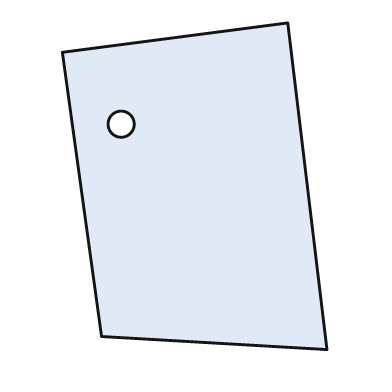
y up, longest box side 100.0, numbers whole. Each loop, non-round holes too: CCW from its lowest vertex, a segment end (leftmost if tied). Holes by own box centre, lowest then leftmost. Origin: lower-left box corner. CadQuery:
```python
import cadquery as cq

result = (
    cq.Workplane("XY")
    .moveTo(81.0, 0.0)
    .lineTo(69.0, 100.0)
    .lineTo(0.0, 91.0)
    .lineTo(12.0, 4.0)
    .close()
    .moveTo(18.0, 69.0)
    .circle(4.0)
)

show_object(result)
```